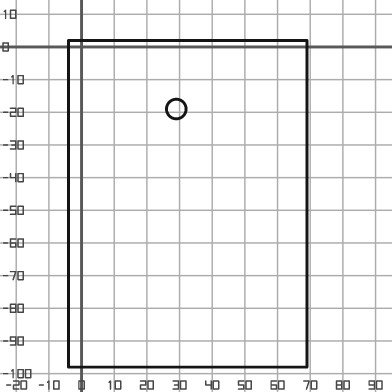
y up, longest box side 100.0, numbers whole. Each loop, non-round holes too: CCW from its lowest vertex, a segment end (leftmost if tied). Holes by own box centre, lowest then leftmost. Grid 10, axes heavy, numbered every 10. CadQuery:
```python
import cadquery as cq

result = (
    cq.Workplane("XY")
    .moveTo(-4.0, -98.0)
    .lineTo(69.0, -98.0)
    .lineTo(69.0, 2.0)
    .lineTo(-4.0, 2.0)
    .close()
    .moveTo(29.0, -19.0)
    .circle(3.0)
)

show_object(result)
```